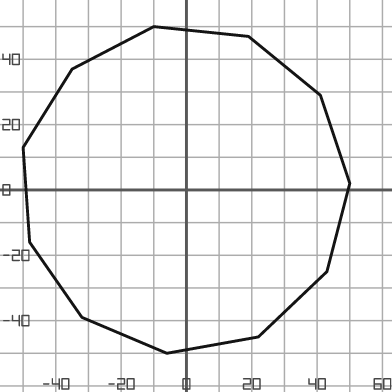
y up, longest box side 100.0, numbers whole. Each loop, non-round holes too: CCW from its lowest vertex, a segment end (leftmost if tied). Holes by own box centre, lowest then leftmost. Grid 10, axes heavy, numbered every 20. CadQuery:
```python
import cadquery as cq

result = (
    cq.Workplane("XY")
    .moveTo(-6.0, -50.0)
    .lineTo(22.0, -45.0)
    .lineTo(43.0, -25.0)
    .lineTo(50.0, 2.0)
    .lineTo(41.0, 29.0)
    .lineTo(19.0, 47.0)
    .lineTo(-10.0, 50.0)
    .lineTo(-35.0, 37.0)
    .lineTo(-50.0, 13.0)
    .lineTo(-48.0, -16.0)
    .lineTo(-32.0, -39.0)
    .close()
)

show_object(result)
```